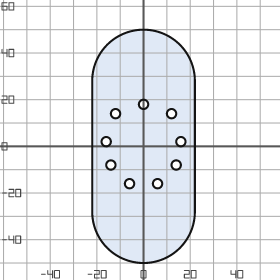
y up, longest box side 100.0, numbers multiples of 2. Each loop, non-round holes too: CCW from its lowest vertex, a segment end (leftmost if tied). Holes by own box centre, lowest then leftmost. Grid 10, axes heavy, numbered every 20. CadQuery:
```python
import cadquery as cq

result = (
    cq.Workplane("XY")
    .moveTo(-22.0, -28.0)
    .threePointArc((0.0, -50.0), (22.0, -28.0))
    .lineTo(22.0, 28.0)
    .threePointArc((0.0, 50.0), (-22.0, 28.0))
    .close()
    .moveTo(-6.0, -16.0)
    .circle(2.0)
    .moveTo(6.0, -16.0)
    .circle(2.0)
    .moveTo(-14.0, -8.0)
    .circle(2.0)
    .moveTo(14.0, -8.0)
    .circle(2.0)
    .moveTo(-16.0, 2.0)
    .circle(2.0)
    .moveTo(16.0, 2.0)
    .circle(2.0)
    .moveTo(-12.0, 14.0)
    .circle(2.0)
    .moveTo(12.0, 14.0)
    .circle(2.0)
    .moveTo(0.0, 18.0)
    .circle(2.0)
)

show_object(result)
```